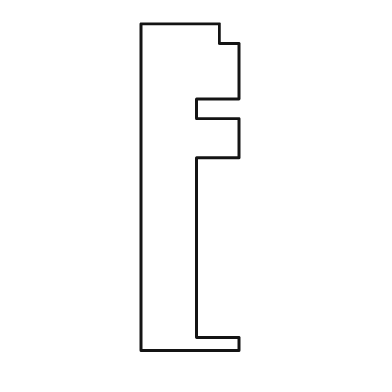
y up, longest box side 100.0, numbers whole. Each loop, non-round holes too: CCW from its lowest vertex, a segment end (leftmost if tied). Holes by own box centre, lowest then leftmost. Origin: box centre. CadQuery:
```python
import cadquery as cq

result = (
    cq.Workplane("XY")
    .moveTo(-15.0, -50.0)
    .lineTo(15.0, -50.0)
    .lineTo(15.0, -46.0)
    .lineTo(2.0, -46.0)
    .lineTo(2.0, 9.0)
    .lineTo(15.0, 9.0)
    .lineTo(15.0, 21.0)
    .lineTo(2.0, 21.0)
    .lineTo(2.0, 27.0)
    .lineTo(15.0, 27.0)
    .lineTo(15.0, 44.0)
    .lineTo(9.0, 44.0)
    .lineTo(9.0, 50.0)
    .lineTo(-15.0, 50.0)
    .close()
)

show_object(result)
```